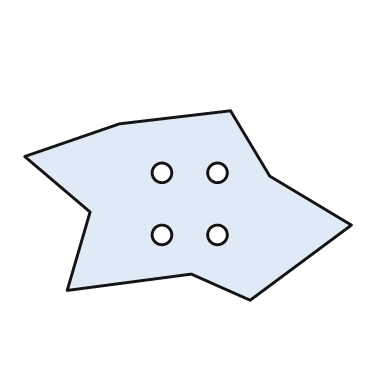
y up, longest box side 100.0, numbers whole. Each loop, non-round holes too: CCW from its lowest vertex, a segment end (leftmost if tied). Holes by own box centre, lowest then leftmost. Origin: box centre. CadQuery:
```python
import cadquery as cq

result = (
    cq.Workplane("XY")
    .moveTo(19.0, -29.0)
    .lineTo(50.0, -6.0)
    .lineTo(25.0, 9.0)
    .lineTo(13.0, 29.0)
    .lineTo(-21.0, 25.0)
    .lineTo(-50.0, 15.0)
    .lineTo(-30.0, -2.0)
    .lineTo(-37.0, -26.0)
    .lineTo(1.0, -21.0)
    .close()
    .moveTo(-8.0, -9.0)
    .circle(3.0)
    .moveTo(9.0, -9.0)
    .circle(3.0)
    .moveTo(-8.0, 10.0)
    .circle(3.0)
    .moveTo(9.0, 10.0)
    .circle(3.0)
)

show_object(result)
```